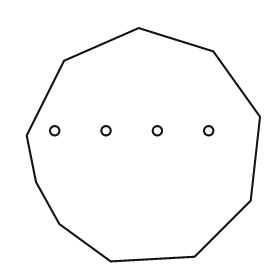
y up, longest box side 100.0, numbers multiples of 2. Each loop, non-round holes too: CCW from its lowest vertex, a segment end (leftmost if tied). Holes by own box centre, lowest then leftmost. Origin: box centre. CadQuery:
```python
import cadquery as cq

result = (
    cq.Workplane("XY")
    .moveTo(-14.0, -50.0)
    .lineTo(22.0, -48.0)
    .lineTo(46.0, -24.0)
    .lineTo(50.0, 12.0)
    .lineTo(30.0, 40.0)
    .lineTo(-2.0, 50.0)
    .lineTo(-34.0, 36.0)
    .lineTo(-50.0, 4.0)
    .lineTo(-46.0, -16.0)
    .lineTo(-36.0, -34.0)
    .close()
    .moveTo(-38.0, 6.0)
    .circle(2.0)
    .moveTo(-16.0, 6.0)
    .circle(2.0)
    .moveTo(6.0, 6.0)
    .circle(2.0)
    .moveTo(28.0, 6.0)
    .circle(2.0)
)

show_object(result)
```